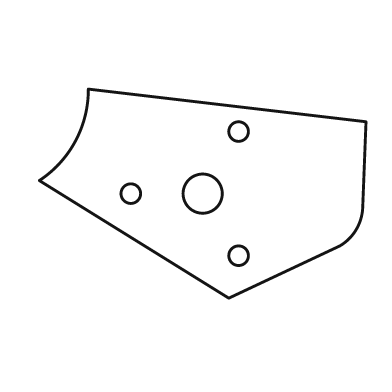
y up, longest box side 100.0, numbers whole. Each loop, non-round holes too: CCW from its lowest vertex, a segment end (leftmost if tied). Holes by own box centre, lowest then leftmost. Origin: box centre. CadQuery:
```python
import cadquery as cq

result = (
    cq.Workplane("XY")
    .moveTo(8.0, -32.0)
    .lineTo(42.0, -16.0)
    .threePointArc((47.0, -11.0), (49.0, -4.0))
    .lineTo(50.0, 22.0)
    .lineTo(-35.0, 32.0)
    .threePointArc((-39.0, 16.0), (-50.0, 4.0))
    .close()
    .moveTo(11.0, -19.0)
    .circle(3.0)
    .moveTo(-22.0, 0.0)
    .circle(3.0)
    .moveTo(0.0, 0.0)
    .circle(6.0)
    .moveTo(11.0, 19.0)
    .circle(3.0)
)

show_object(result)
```